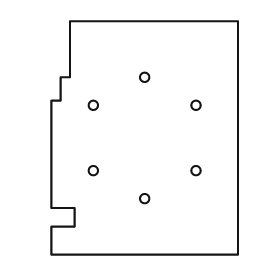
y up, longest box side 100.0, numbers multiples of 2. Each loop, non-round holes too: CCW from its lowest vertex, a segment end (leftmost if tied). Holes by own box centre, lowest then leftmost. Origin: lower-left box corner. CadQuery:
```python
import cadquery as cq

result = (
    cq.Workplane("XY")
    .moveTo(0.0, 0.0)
    .lineTo(80.0, 0.0)
    .lineTo(80.0, 100.0)
    .lineTo(8.0, 100.0)
    .lineTo(8.0, 76.0)
    .lineTo(4.0, 76.0)
    .lineTo(4.0, 66.0)
    .lineTo(0.0, 66.0)
    .lineTo(0.0, 20.0)
    .lineTo(10.0, 20.0)
    .lineTo(10.0, 12.0)
    .lineTo(0.0, 12.0)
    .close()
    .moveTo(40.0, 24.0)
    .circle(2.0)
    .moveTo(18.0, 36.0)
    .circle(2.0)
    .moveTo(62.0, 36.0)
    .circle(2.0)
    .moveTo(18.0, 64.0)
    .circle(2.0)
    .moveTo(62.0, 64.0)
    .circle(2.0)
    .moveTo(40.0, 76.0)
    .circle(2.0)
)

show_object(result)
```